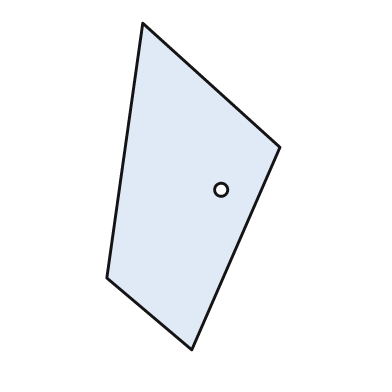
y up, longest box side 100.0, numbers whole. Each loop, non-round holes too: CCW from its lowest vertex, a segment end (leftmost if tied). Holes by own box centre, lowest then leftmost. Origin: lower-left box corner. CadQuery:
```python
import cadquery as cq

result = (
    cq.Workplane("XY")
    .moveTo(26.0, 0.0)
    .lineTo(53.0, 62.0)
    .lineTo(11.0, 100.0)
    .lineTo(0.0, 22.0)
    .close()
    .moveTo(35.0, 49.0)
    .circle(2.0)
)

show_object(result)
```